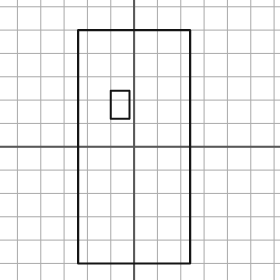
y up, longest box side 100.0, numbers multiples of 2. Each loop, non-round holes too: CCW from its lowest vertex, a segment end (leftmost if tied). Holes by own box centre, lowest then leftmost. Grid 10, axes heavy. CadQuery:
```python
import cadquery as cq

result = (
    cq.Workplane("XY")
    .moveTo(-24.0, -50.0)
    .lineTo(24.0, -50.0)
    .lineTo(24.0, 50.0)
    .lineTo(-24.0, 50.0)
    .close()
    .moveTo(-10.0, 12.0)
    .lineTo(-2.0, 12.0)
    .lineTo(-2.0, 24.0)
    .lineTo(-10.0, 24.0)
    .close()
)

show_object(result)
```